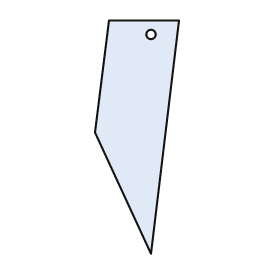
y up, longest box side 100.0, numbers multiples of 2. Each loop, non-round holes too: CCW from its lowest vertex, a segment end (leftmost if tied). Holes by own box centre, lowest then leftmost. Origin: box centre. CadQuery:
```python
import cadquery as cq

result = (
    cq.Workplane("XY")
    .moveTo(6.0, -50.0)
    .lineTo(18.0, 50.0)
    .lineTo(-12.0, 50.0)
    .lineTo(-18.0, 2.0)
    .close()
    .moveTo(6.0, 44.0)
    .circle(2.0)
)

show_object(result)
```